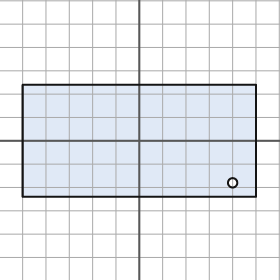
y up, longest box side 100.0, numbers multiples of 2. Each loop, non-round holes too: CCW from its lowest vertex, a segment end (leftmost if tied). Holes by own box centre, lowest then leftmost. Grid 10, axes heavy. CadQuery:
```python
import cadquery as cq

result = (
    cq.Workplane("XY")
    .moveTo(-50.0, -24.0)
    .lineTo(50.0, -24.0)
    .lineTo(50.0, 24.0)
    .lineTo(-50.0, 24.0)
    .close()
    .moveTo(40.0, -18.0)
    .circle(2.0)
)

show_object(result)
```